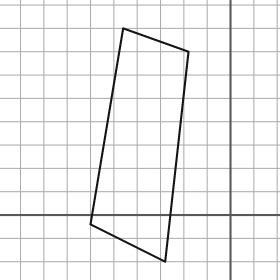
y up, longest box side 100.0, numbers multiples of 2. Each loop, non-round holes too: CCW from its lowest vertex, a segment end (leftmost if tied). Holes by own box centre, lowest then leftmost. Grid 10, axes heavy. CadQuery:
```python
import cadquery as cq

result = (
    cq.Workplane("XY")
    .moveTo(-28.0, -20.0)
    .lineTo(-18.0, 70.0)
    .lineTo(-46.0, 80.0)
    .lineTo(-60.0, -4.0)
    .close()
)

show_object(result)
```